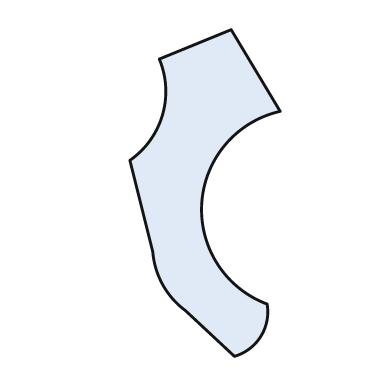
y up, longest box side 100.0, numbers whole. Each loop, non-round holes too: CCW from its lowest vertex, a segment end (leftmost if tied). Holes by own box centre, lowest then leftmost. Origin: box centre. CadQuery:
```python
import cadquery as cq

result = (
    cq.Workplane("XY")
    .moveTo(9.0, -50.0)
    .threePointArc((17.0, -44.0), (19.0, -34.0))
    .threePointArc((-1.0, -3.0), (23.0, 25.0))
    .lineTo(8.0, 50.0)
    .lineTo(-14.0, 41.0)
    .threePointArc((-13.0, 24.0), (-23.0, 10.0))
    .lineTo(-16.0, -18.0)
    .threePointArc((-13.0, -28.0), (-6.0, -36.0))
    .close()
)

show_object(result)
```